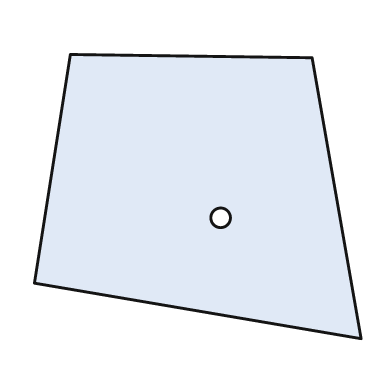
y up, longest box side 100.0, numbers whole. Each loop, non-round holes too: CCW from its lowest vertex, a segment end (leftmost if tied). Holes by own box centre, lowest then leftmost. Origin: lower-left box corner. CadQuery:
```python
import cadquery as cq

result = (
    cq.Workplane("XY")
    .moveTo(100.0, 0.0)
    .lineTo(85.0, 86.0)
    .lineTo(11.0, 87.0)
    .lineTo(0.0, 17.0)
    .close()
    .moveTo(57.0, 37.0)
    .circle(3.0)
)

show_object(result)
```